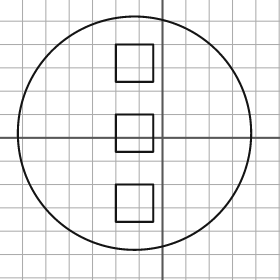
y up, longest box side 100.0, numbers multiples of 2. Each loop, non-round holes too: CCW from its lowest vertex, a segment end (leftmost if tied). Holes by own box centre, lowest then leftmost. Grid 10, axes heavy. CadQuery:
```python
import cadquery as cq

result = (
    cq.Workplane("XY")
    .moveTo(-12.0, 2.0)
    .circle(50.0)
    .moveTo(-20.0, -36.0)
    .lineTo(-4.0, -36.0)
    .lineTo(-4.0, -20.0)
    .lineTo(-20.0, -20.0)
    .close()
    .moveTo(-20.0, -6.0)
    .lineTo(-4.0, -6.0)
    .lineTo(-4.0, 10.0)
    .lineTo(-20.0, 10.0)
    .close()
    .moveTo(-20.0, 24.0)
    .lineTo(-4.0, 24.0)
    .lineTo(-4.0, 40.0)
    .lineTo(-20.0, 40.0)
    .close()
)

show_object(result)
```